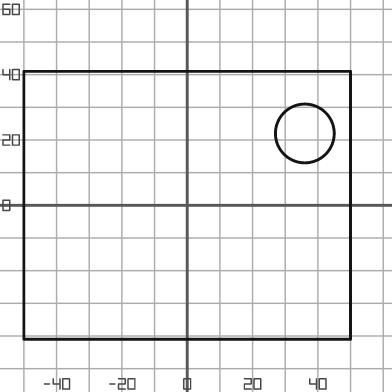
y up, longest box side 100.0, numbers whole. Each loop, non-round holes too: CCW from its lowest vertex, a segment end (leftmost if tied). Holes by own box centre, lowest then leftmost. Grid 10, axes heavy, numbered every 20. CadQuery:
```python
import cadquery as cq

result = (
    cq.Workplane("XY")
    .moveTo(-50.0, -41.0)
    .lineTo(50.0, -41.0)
    .lineTo(50.0, 41.0)
    .lineTo(-50.0, 41.0)
    .close()
    .moveTo(36.0, 22.0)
    .circle(9.0)
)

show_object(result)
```